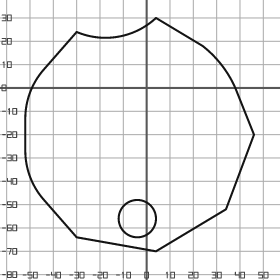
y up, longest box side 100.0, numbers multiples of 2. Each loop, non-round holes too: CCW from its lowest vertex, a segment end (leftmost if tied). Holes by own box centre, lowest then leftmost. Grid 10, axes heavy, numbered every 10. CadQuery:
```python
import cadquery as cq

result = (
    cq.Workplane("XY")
    .moveTo(4.0, -70.0)
    .lineTo(34.0, -52.0)
    .lineTo(46.0, -20.0)
    .lineTo(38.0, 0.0)
    .threePointArc((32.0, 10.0), (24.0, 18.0))
    .lineTo(4.0, 30.0)
    .threePointArc((-12.0, 22.0), (-30.0, 24.0))
    .lineTo(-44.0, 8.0)
    .threePointArc((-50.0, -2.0), (-52.0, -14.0))
    .lineTo(-52.0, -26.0)
    .threePointArc((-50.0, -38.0), (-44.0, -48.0))
    .lineTo(-30.0, -64.0)
    .close()
    .moveTo(-4.0, -56.0)
    .circle(8.0)
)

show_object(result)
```